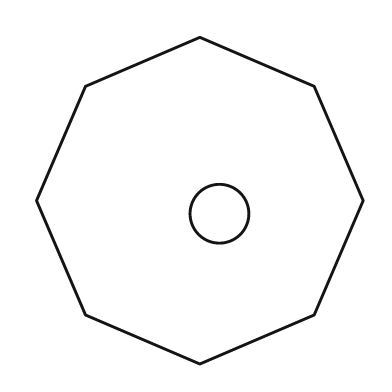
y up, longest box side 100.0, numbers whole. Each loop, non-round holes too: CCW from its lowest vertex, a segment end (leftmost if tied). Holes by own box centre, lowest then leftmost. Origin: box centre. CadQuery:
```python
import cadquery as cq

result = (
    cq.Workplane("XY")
    .moveTo(0.0, -50.0)
    .lineTo(35.0, -35.0)
    .lineTo(50.0, 0.0)
    .lineTo(35.0, 35.0)
    .lineTo(0.0, 50.0)
    .lineTo(-35.0, 35.0)
    .lineTo(-50.0, 0.0)
    .lineTo(-35.0, -35.0)
    .close()
    .moveTo(6.0, -4.0)
    .circle(9.0)
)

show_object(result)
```